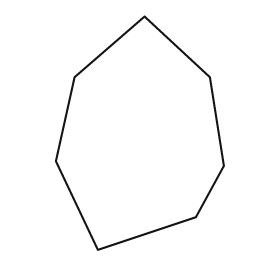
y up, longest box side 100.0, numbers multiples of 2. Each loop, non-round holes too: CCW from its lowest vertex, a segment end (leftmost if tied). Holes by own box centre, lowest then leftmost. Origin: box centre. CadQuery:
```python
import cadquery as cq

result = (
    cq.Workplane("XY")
    .moveTo(-18.0, -50.0)
    .lineTo(24.0, -36.0)
    .lineTo(36.0, -14.0)
    .lineTo(30.0, 24.0)
    .lineTo(2.0, 50.0)
    .lineTo(-28.0, 24.0)
    .lineTo(-36.0, -12.0)
    .close()
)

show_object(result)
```